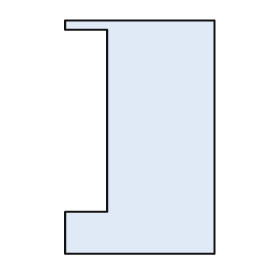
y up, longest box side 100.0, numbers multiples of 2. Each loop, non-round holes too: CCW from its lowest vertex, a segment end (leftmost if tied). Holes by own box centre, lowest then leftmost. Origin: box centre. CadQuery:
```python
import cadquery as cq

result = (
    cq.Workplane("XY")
    .moveTo(-32.0, -50.0)
    .lineTo(32.0, -50.0)
    .lineTo(32.0, 50.0)
    .lineTo(-32.0, 50.0)
    .lineTo(-32.0, 46.0)
    .lineTo(-14.0, 46.0)
    .lineTo(-14.0, -32.0)
    .lineTo(-32.0, -32.0)
    .close()
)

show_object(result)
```